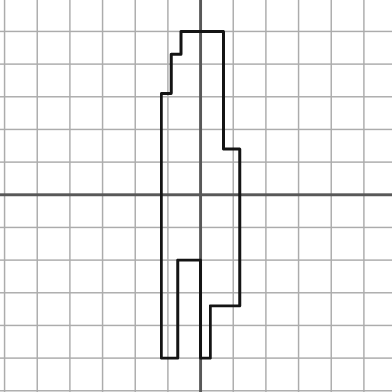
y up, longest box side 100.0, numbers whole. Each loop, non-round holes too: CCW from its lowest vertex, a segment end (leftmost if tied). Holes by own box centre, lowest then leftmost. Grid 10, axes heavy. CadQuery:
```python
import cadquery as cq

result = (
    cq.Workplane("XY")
    .moveTo(-12.0, -50.0)
    .lineTo(-7.0, -50.0)
    .lineTo(-7.0, -20.0)
    .lineTo(0.0, -20.0)
    .lineTo(0.0, -50.0)
    .lineTo(3.0, -50.0)
    .lineTo(3.0, -34.0)
    .lineTo(12.0, -34.0)
    .lineTo(12.0, 14.0)
    .lineTo(7.0, 14.0)
    .lineTo(7.0, 50.0)
    .lineTo(-6.0, 50.0)
    .lineTo(-6.0, 43.0)
    .lineTo(-9.0, 43.0)
    .lineTo(-9.0, 31.0)
    .lineTo(-12.0, 31.0)
    .close()
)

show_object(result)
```